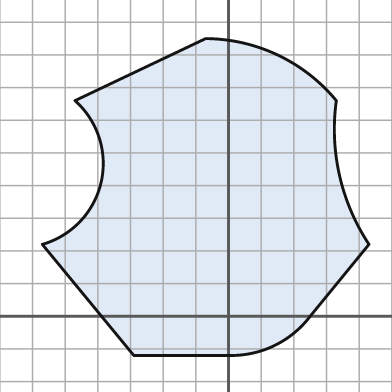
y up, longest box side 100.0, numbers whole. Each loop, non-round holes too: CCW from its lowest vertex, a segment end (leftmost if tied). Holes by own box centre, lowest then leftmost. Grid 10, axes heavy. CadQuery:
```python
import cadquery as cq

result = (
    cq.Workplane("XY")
    .moveTo(-29.0, -12.0)
    .lineTo(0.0, -12.0)
    .threePointArc((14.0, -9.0), (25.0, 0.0))
    .lineTo(43.0, 22.0)
    .threePointArc((34.0, 43.0), (33.0, 66.0))
    .threePointArc((15.0, 80.0), (-7.0, 85.0))
    .lineTo(-47.0, 66.0)
    .threePointArc((-39.0, 41.0), (-57.0, 22.0))
    .close()
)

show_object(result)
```